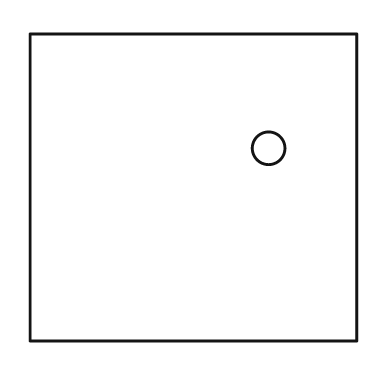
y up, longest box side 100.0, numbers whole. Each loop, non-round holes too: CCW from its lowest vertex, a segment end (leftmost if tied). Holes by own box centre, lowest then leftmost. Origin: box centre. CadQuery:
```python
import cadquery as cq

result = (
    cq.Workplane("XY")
    .moveTo(-50.0, -47.0)
    .lineTo(50.0, -47.0)
    .lineTo(50.0, 47.0)
    .lineTo(-50.0, 47.0)
    .close()
    .moveTo(23.0, 12.0)
    .circle(5.0)
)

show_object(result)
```